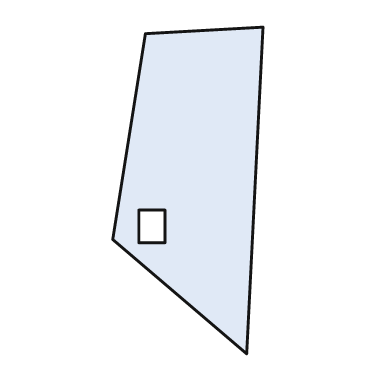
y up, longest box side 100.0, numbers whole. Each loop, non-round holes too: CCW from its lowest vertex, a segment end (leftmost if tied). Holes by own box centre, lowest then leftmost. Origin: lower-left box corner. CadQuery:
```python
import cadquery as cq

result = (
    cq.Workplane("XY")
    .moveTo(41.0, 0.0)
    .lineTo(46.0, 100.0)
    .lineTo(10.0, 98.0)
    .lineTo(0.0, 35.0)
    .close()
    .moveTo(8.0, 34.0)
    .lineTo(16.0, 34.0)
    .lineTo(16.0, 44.0)
    .lineTo(8.0, 44.0)
    .close()
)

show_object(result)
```